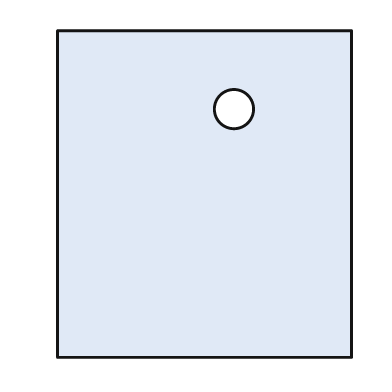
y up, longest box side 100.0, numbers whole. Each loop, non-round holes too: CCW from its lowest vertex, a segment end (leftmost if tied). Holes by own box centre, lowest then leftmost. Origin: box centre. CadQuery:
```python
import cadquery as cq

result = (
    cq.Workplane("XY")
    .moveTo(-45.0, -50.0)
    .lineTo(45.0, -50.0)
    .lineTo(45.0, 50.0)
    .lineTo(-45.0, 50.0)
    .close()
    .moveTo(9.0, 26.0)
    .circle(6.0)
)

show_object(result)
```